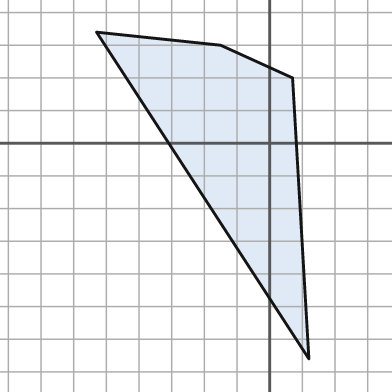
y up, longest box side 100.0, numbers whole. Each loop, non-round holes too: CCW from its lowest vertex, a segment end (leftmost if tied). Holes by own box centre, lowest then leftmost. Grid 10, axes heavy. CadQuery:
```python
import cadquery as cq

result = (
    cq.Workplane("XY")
    .moveTo(12.0, -66.0)
    .lineTo(7.0, 20.0)
    .lineTo(-15.0, 30.0)
    .lineTo(-53.0, 34.0)
    .close()
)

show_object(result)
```